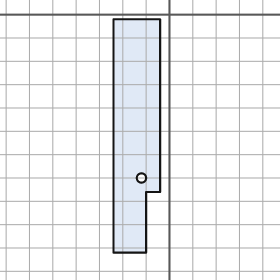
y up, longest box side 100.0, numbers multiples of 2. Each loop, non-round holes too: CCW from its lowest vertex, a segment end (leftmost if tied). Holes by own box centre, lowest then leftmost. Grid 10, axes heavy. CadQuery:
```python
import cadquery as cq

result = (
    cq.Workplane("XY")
    .moveTo(-24.0, -102.0)
    .lineTo(-10.0, -102.0)
    .lineTo(-10.0, -76.0)
    .lineTo(-4.0, -76.0)
    .lineTo(-4.0, -2.0)
    .lineTo(-24.0, -2.0)
    .close()
    .moveTo(-12.0, -70.0)
    .circle(2.0)
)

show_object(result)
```